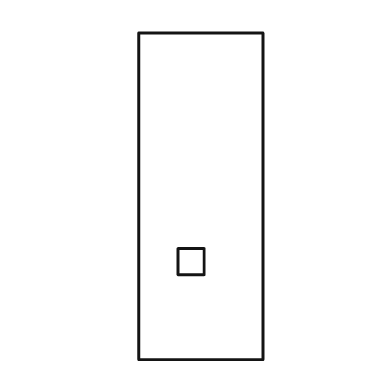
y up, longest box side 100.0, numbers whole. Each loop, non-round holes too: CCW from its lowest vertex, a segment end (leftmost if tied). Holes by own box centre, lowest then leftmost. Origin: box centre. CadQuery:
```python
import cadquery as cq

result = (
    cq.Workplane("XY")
    .moveTo(-19.0, -50.0)
    .lineTo(19.0, -50.0)
    .lineTo(19.0, 50.0)
    .lineTo(-19.0, 50.0)
    .close()
    .moveTo(-7.0, -24.0)
    .lineTo(1.0, -24.0)
    .lineTo(1.0, -16.0)
    .lineTo(-7.0, -16.0)
    .close()
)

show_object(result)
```